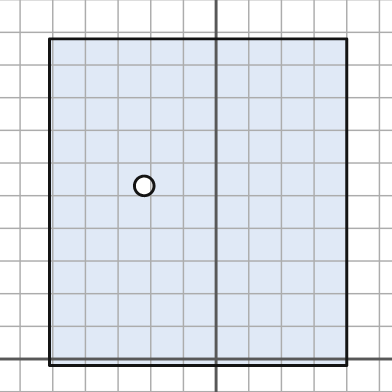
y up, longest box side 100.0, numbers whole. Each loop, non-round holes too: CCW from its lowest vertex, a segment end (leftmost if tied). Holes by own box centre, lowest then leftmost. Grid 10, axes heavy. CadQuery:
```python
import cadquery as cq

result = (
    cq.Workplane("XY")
    .moveTo(-51.0, -2.0)
    .lineTo(40.0, -2.0)
    .lineTo(40.0, 98.0)
    .lineTo(-51.0, 98.0)
    .close()
    .moveTo(-22.0, 53.0)
    .circle(3.0)
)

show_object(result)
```